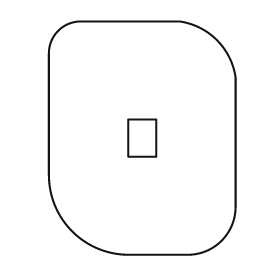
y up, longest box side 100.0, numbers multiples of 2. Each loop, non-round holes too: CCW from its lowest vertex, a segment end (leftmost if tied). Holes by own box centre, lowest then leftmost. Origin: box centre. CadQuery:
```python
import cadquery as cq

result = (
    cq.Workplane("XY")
    .moveTo(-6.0, -50.0)
    .lineTo(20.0, -50.0)
    .threePointArc((34.0, -44.0), (40.0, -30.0))
    .lineTo(40.0, 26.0)
    .threePointArc((32.0, 42.0), (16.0, 50.0))
    .lineTo(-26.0, 50.0)
    .threePointArc((-36.0, 46.0), (-40.0, 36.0))
    .lineTo(-40.0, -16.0)
    .threePointArc((-30.0, -40.0), (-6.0, -50.0))
    .close()
    .moveTo(-6.0, -8.0)
    .lineTo(6.0, -8.0)
    .lineTo(6.0, 8.0)
    .lineTo(-6.0, 8.0)
    .close()
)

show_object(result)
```